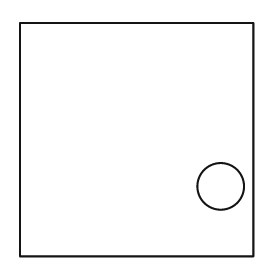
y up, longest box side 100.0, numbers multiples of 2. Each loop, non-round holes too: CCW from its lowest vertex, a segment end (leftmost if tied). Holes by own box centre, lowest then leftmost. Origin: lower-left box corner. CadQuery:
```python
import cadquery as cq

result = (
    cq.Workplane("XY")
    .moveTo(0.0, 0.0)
    .lineTo(100.0, 0.0)
    .lineTo(100.0, 100.0)
    .lineTo(0.0, 100.0)
    .close()
    .moveTo(86.0, 30.0)
    .circle(10.0)
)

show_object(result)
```